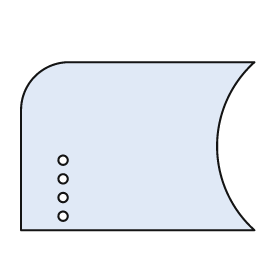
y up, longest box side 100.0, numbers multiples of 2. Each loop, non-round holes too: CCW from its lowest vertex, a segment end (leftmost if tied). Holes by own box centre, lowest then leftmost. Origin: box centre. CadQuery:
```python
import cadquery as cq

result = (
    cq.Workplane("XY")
    .moveTo(-50.0, -36.0)
    .lineTo(50.0, -36.0)
    .threePointArc((34.0, 0.0), (50.0, 36.0))
    .lineTo(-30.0, 36.0)
    .threePointArc((-44.0, 30.0), (-50.0, 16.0))
    .close()
    .moveTo(-32.0, -30.0)
    .circle(2.0)
    .moveTo(-32.0, -22.0)
    .circle(2.0)
    .moveTo(-32.0, -14.0)
    .circle(2.0)
    .moveTo(-32.0, -6.0)
    .circle(2.0)
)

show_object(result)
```